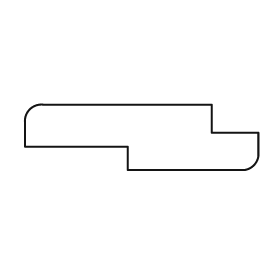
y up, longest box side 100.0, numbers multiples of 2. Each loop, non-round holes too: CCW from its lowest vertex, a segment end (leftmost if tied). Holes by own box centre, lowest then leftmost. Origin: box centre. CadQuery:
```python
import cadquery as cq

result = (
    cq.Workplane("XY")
    .moveTo(-6.0, -14.0)
    .lineTo(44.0, -14.0)
    .threePointArc((48.0, -12.0), (50.0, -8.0))
    .lineTo(50.0, 2.0)
    .lineTo(30.0, 2.0)
    .lineTo(30.0, 14.0)
    .lineTo(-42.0, 14.0)
    .threePointArc((-48.0, 12.0), (-50.0, 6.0))
    .lineTo(-50.0, -4.0)
    .lineTo(-6.0, -4.0)
    .close()
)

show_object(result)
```